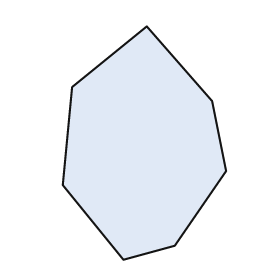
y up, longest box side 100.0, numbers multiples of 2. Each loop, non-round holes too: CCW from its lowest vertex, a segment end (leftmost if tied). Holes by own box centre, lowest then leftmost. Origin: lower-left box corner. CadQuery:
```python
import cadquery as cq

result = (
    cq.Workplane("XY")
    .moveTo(26.0, 0.0)
    .lineTo(48.0, 6.0)
    .lineTo(70.0, 38.0)
    .lineTo(64.0, 68.0)
    .lineTo(36.0, 100.0)
    .lineTo(4.0, 74.0)
    .lineTo(0.0, 32.0)
    .close()
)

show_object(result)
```